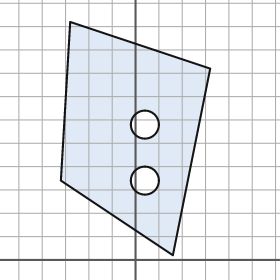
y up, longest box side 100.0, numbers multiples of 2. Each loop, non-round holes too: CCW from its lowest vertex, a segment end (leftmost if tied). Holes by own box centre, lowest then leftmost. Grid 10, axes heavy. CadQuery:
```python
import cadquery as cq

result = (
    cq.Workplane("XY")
    .moveTo(16.0, 2.0)
    .lineTo(32.0, 82.0)
    .lineTo(-28.0, 102.0)
    .lineTo(-32.0, 34.0)
    .close()
    .moveTo(4.0, 34.0)
    .circle(6.0)
    .moveTo(4.0, 58.0)
    .circle(6.0)
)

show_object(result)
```